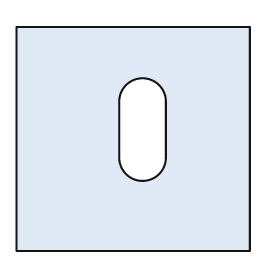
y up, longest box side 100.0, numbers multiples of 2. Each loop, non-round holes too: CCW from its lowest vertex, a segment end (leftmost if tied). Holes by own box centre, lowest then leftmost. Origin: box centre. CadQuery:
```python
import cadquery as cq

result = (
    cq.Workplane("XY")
    .moveTo(-50.0, -48.0)
    .lineTo(50.0, -48.0)
    .lineTo(50.0, 48.0)
    .lineTo(-50.0, 48.0)
    .close()
    .moveTo(-6.0, -8.0)
    .threePointArc((4.0, -18.0), (14.0, -8.0))
    .lineTo(14.0, 16.0)
    .threePointArc((4.0, 26.0), (-6.0, 16.0))
    .close()
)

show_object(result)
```